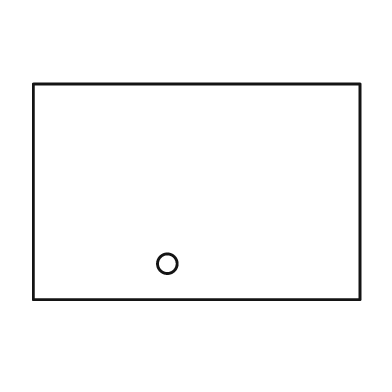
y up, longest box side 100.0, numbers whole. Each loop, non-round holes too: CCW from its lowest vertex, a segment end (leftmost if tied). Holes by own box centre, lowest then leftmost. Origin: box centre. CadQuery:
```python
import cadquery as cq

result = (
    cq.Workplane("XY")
    .moveTo(-50.0, -33.0)
    .lineTo(50.0, -33.0)
    .lineTo(50.0, 33.0)
    .lineTo(-50.0, 33.0)
    .close()
    .moveTo(-9.0, -22.0)
    .circle(3.0)
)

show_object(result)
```